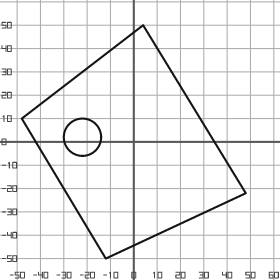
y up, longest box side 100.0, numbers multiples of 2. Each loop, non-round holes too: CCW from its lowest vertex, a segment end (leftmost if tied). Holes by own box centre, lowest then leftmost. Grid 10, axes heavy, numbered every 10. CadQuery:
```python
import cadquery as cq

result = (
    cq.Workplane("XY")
    .moveTo(-12.0, -50.0)
    .lineTo(48.0, -22.0)
    .lineTo(4.0, 50.0)
    .lineTo(-48.0, 10.0)
    .close()
    .moveTo(-22.0, 2.0)
    .circle(8.0)
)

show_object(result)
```